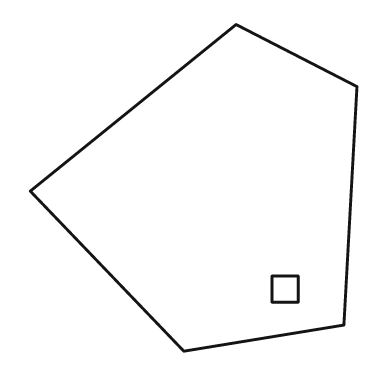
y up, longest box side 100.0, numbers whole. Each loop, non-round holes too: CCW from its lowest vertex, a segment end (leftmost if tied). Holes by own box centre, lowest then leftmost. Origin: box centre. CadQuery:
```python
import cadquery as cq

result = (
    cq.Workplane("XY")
    .moveTo(-3.0, -50.0)
    .lineTo(46.0, -42.0)
    .lineTo(50.0, 31.0)
    .lineTo(13.0, 50.0)
    .lineTo(-50.0, -1.0)
    .close()
    .moveTo(24.0, -35.0)
    .lineTo(32.0, -35.0)
    .lineTo(32.0, -27.0)
    .lineTo(24.0, -27.0)
    .close()
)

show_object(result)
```